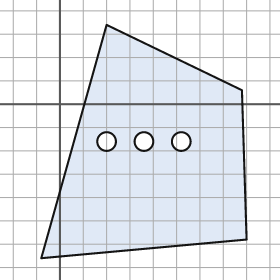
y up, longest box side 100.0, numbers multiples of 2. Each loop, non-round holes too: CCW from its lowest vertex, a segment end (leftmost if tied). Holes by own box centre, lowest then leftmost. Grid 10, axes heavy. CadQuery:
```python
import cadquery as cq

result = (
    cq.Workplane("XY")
    .moveTo(-8.0, -66.0)
    .lineTo(80.0, -58.0)
    .lineTo(78.0, 6.0)
    .lineTo(20.0, 34.0)
    .close()
    .moveTo(20.0, -16.0)
    .circle(4.0)
    .moveTo(36.0, -16.0)
    .circle(4.0)
    .moveTo(52.0, -16.0)
    .circle(4.0)
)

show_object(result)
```